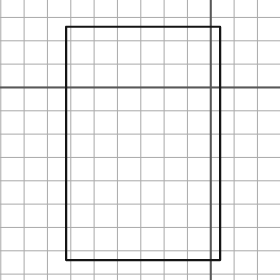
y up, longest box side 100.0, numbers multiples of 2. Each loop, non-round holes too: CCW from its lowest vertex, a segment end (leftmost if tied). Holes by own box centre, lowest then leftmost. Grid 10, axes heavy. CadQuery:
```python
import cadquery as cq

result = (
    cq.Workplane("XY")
    .moveTo(-62.0, -74.0)
    .lineTo(4.0, -74.0)
    .lineTo(4.0, 26.0)
    .lineTo(-62.0, 26.0)
    .close()
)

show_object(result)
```